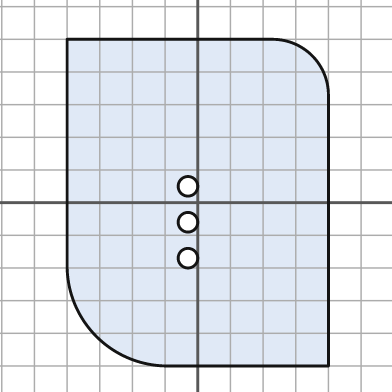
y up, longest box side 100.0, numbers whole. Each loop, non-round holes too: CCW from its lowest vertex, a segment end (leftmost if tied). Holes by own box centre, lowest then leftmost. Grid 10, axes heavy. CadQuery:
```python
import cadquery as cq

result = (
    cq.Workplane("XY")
    .moveTo(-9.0, -50.0)
    .lineTo(40.0, -50.0)
    .lineTo(40.0, 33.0)
    .threePointArc((35.0, 45.0), (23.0, 50.0))
    .lineTo(-40.0, 50.0)
    .lineTo(-40.0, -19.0)
    .threePointArc((-31.0, -41.0), (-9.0, -50.0))
    .close()
    .moveTo(-3.0, -17.0)
    .circle(3.0)
    .moveTo(-3.0, -6.0)
    .circle(3.0)
    .moveTo(-3.0, 5.0)
    .circle(3.0)
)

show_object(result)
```